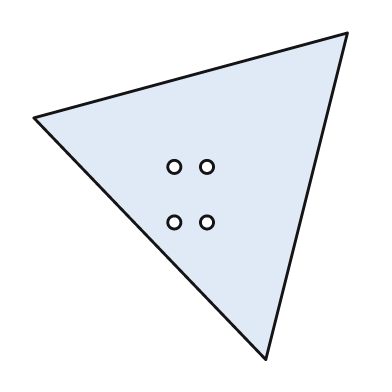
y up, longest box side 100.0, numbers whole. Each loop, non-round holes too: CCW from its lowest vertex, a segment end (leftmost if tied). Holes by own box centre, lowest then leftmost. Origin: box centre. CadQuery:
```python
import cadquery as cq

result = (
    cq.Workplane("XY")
    .moveTo(23.0, -50.0)
    .lineTo(48.0, 50.0)
    .lineTo(-48.0, 24.0)
    .close()
    .moveTo(-5.0, -8.0)
    .circle(2.0)
    .moveTo(5.0, -8.0)
    .circle(2.0)
    .moveTo(-5.0, 9.0)
    .circle(2.0)
    .moveTo(5.0, 9.0)
    .circle(2.0)
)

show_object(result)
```